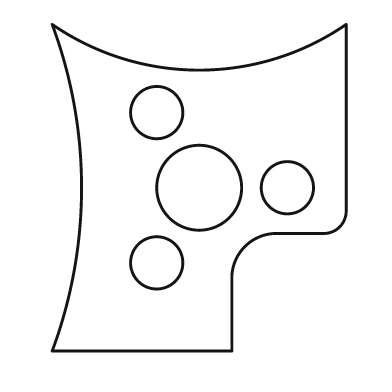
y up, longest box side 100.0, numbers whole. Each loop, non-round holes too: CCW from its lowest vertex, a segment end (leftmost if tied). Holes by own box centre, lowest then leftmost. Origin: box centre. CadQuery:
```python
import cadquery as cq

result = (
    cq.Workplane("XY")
    .moveTo(-45.0, -50.0)
    .lineTo(10.0, -50.0)
    .lineTo(10.0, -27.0)
    .threePointArc((14.0, -18.0), (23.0, -14.0))
    .lineTo(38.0, -14.0)
    .threePointArc((43.0, -12.0), (45.0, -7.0))
    .lineTo(45.0, 50.0)
    .threePointArc((0.0, 36.0), (-45.0, 50.0))
    .threePointArc((-36.0, 0.0), (-45.0, -50.0))
    .close()
    .moveTo(-13.0, -23.0)
    .circle(8.0)
    .moveTo(0.0, 0.0)
    .circle(13.0)
    .moveTo(27.0, 0.0)
    .circle(8.0)
    .moveTo(-13.0, 23.0)
    .circle(8.0)
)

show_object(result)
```